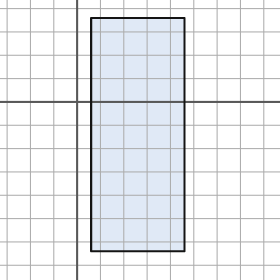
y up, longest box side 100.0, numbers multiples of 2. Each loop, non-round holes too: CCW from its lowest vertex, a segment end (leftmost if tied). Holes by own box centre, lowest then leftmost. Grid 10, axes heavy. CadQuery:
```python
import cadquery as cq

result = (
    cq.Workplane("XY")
    .moveTo(6.0, -64.0)
    .lineTo(46.0, -64.0)
    .lineTo(46.0, 36.0)
    .lineTo(6.0, 36.0)
    .close()
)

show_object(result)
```